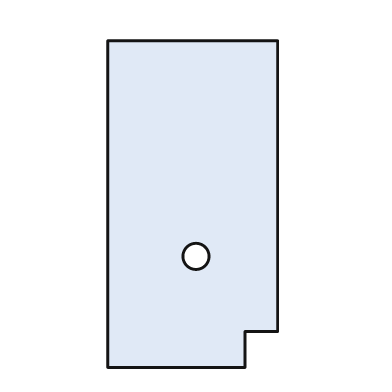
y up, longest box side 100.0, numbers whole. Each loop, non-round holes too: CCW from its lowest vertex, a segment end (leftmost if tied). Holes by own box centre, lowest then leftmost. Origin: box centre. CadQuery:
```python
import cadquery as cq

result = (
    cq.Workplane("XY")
    .moveTo(-26.0, -50.0)
    .lineTo(16.0, -50.0)
    .lineTo(16.0, -39.0)
    .lineTo(26.0, -39.0)
    .lineTo(26.0, 50.0)
    .lineTo(-26.0, 50.0)
    .close()
    .moveTo(1.0, -16.0)
    .circle(4.0)
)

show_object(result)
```